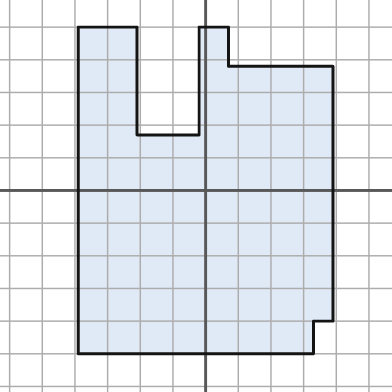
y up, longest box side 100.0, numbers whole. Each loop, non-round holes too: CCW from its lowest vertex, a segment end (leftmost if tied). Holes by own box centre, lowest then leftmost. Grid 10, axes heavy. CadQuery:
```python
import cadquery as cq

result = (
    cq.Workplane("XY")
    .moveTo(-39.0, -50.0)
    .lineTo(33.0, -50.0)
    .lineTo(33.0, -40.0)
    .lineTo(39.0, -40.0)
    .lineTo(39.0, 38.0)
    .lineTo(7.0, 38.0)
    .lineTo(7.0, 50.0)
    .lineTo(-2.0, 50.0)
    .lineTo(-2.0, 17.0)
    .lineTo(-21.0, 17.0)
    .lineTo(-21.0, 50.0)
    .lineTo(-39.0, 50.0)
    .close()
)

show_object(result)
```